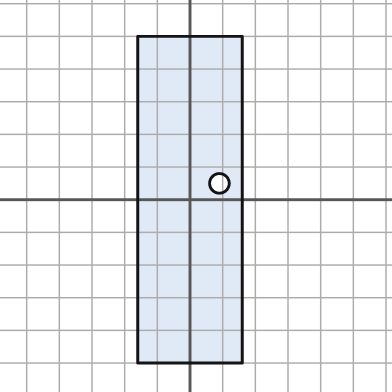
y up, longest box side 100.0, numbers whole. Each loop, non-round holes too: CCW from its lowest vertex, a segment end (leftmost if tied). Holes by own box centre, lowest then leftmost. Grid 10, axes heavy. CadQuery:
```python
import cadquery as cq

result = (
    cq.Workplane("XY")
    .moveTo(-16.0, -50.0)
    .lineTo(16.0, -50.0)
    .lineTo(16.0, 50.0)
    .lineTo(-16.0, 50.0)
    .close()
    .moveTo(9.0, 5.0)
    .circle(3.0)
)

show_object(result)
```